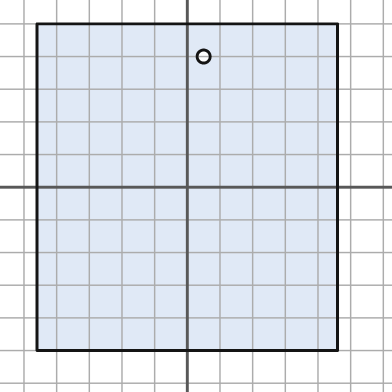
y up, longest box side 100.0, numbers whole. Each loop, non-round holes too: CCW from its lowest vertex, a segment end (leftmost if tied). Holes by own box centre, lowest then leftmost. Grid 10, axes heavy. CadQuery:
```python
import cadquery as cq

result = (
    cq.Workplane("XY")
    .moveTo(-46.0, -50.0)
    .lineTo(46.0, -50.0)
    .lineTo(46.0, 50.0)
    .lineTo(-46.0, 50.0)
    .close()
    .moveTo(5.0, 40.0)
    .circle(2.0)
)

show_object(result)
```